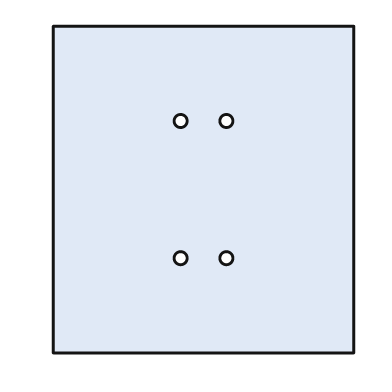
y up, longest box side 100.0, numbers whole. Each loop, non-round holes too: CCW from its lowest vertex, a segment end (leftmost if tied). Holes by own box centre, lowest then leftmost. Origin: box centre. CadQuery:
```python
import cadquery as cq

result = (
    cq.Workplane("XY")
    .moveTo(-46.0, -50.0)
    .lineTo(46.0, -50.0)
    .lineTo(46.0, 50.0)
    .lineTo(-46.0, 50.0)
    .close()
    .moveTo(-7.0, -21.0)
    .circle(2.0)
    .moveTo(7.0, -21.0)
    .circle(2.0)
    .moveTo(-7.0, 21.0)
    .circle(2.0)
    .moveTo(7.0, 21.0)
    .circle(2.0)
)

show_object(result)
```